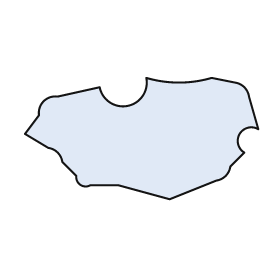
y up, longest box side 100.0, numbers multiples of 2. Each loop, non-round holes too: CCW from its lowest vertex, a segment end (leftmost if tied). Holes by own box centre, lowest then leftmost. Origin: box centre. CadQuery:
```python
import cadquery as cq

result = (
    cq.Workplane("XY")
    .moveTo(12.0, -26.0)
    .lineTo(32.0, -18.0)
    .threePointArc((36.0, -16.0), (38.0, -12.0))
    .lineTo(44.0, -6.0)
    .threePointArc((42.0, 2.0), (50.0, 4.0))
    .lineTo(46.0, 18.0)
    .threePointArc((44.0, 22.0), (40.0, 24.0))
    .lineTo(30.0, 26.0)
    .threePointArc((16.0, 24.0), (2.0, 26.0))
    .threePointArc((-6.0, 14.0), (-18.0, 22.0))
    .lineTo(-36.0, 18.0)
    .threePointArc((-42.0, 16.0), (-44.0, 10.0))
    .lineTo(-50.0, 2.0)
    .lineTo(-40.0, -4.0)
    .threePointArc((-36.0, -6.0), (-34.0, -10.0))
    .lineTo(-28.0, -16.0)
    .threePointArc((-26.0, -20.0), (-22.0, -20.0))
    .lineTo(-10.0, -20.0)
    .close()
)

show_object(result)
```